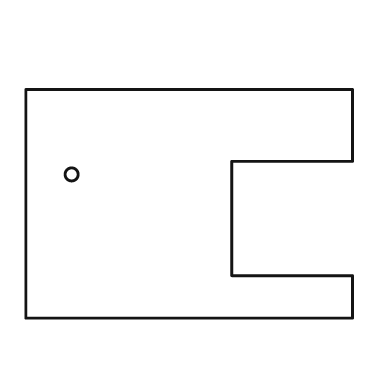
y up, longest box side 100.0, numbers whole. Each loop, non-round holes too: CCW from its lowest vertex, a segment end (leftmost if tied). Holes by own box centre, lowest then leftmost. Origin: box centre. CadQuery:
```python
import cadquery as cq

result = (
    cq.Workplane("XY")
    .moveTo(-50.0, -35.0)
    .lineTo(50.0, -35.0)
    .lineTo(50.0, -22.0)
    .lineTo(13.0, -22.0)
    .lineTo(13.0, 13.0)
    .lineTo(50.0, 13.0)
    .lineTo(50.0, 35.0)
    .lineTo(-50.0, 35.0)
    .close()
    .moveTo(-36.0, 9.0)
    .circle(2.0)
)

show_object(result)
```